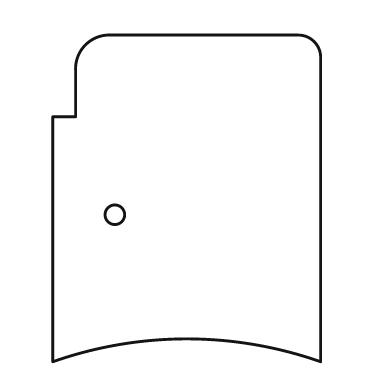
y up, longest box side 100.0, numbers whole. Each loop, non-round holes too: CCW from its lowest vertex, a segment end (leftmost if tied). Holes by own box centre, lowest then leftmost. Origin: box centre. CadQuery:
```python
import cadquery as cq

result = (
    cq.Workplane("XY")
    .moveTo(-41.0, -50.0)
    .threePointArc((0.0, -43.0), (41.0, -50.0))
    .lineTo(41.0, 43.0)
    .threePointArc((39.0, 48.0), (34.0, 50.0))
    .lineTo(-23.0, 50.0)
    .threePointArc((-31.0, 47.0), (-34.0, 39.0))
    .lineTo(-34.0, 25.0)
    .lineTo(-41.0, 25.0)
    .close()
    .moveTo(-22.0, -5.0)
    .circle(3.0)
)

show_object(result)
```